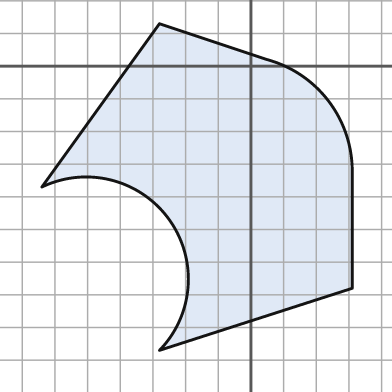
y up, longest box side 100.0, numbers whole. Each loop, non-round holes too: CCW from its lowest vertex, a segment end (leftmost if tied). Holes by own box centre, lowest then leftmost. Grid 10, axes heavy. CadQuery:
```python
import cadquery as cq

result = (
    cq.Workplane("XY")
    .moveTo(-28.0, -87.0)
    .lineTo(31.0, -68.0)
    .lineTo(31.0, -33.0)
    .threePointArc((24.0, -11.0), (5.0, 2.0))
    .lineTo(-28.0, 13.0)
    .lineTo(-64.0, -37.0)
    .threePointArc((-25.0, -47.0), (-28.0, -87.0))
    .close()
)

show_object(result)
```